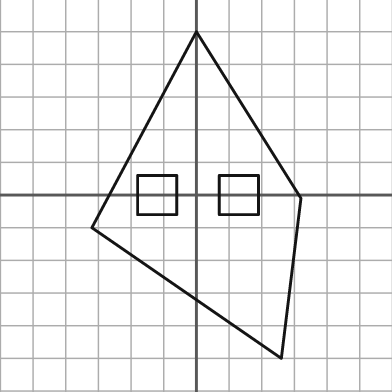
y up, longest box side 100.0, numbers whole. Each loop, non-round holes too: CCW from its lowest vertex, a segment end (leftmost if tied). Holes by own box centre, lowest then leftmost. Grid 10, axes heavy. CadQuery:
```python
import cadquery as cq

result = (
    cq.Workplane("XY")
    .moveTo(26.0, -50.0)
    .lineTo(32.0, -1.0)
    .lineTo(0.0, 50.0)
    .lineTo(-32.0, -10.0)
    .close()
    .moveTo(-18.0, -6.0)
    .lineTo(-6.0, -6.0)
    .lineTo(-6.0, 6.0)
    .lineTo(-18.0, 6.0)
    .close()
    .moveTo(7.0, -6.0)
    .lineTo(19.0, -6.0)
    .lineTo(19.0, 6.0)
    .lineTo(7.0, 6.0)
    .close()
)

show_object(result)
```